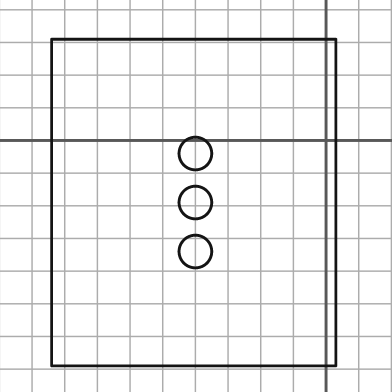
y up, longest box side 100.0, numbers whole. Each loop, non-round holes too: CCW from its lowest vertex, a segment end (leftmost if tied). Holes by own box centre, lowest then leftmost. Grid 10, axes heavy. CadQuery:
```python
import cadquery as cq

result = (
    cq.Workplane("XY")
    .moveTo(-84.0, -69.0)
    .lineTo(3.0, -69.0)
    .lineTo(3.0, 31.0)
    .lineTo(-84.0, 31.0)
    .close()
    .moveTo(-40.0, -34.0)
    .circle(5.0)
    .moveTo(-40.0, -19.0)
    .circle(5.0)
    .moveTo(-40.0, -4.0)
    .circle(5.0)
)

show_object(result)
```